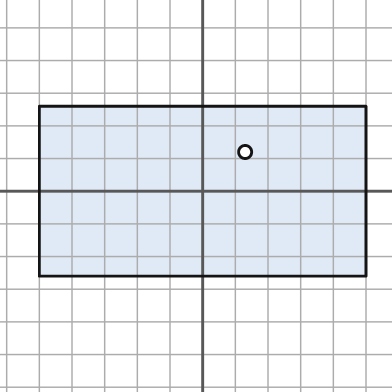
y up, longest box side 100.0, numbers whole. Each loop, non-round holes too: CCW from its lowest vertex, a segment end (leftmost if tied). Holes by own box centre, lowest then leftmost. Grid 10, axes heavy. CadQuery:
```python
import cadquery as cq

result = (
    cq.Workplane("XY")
    .moveTo(-50.0, -26.0)
    .lineTo(50.0, -26.0)
    .lineTo(50.0, 26.0)
    .lineTo(-50.0, 26.0)
    .close()
    .moveTo(13.0, 12.0)
    .circle(2.0)
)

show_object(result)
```